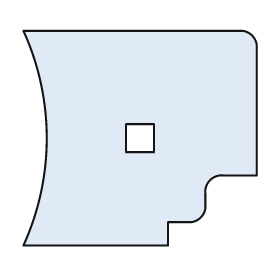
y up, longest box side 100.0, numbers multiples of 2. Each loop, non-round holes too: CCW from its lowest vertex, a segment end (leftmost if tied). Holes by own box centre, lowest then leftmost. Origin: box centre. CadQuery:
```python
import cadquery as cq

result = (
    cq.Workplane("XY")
    .moveTo(-50.0, -46.0)
    .lineTo(12.0, -46.0)
    .lineTo(12.0, -36.0)
    .lineTo(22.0, -36.0)
    .threePointArc((26.0, -34.0), (28.0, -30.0))
    .lineTo(28.0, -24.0)
    .threePointArc((30.0, -18.0), (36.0, -16.0))
    .lineTo(50.0, -16.0)
    .lineTo(50.0, 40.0)
    .threePointArc((48.0, 44.0), (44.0, 46.0))
    .lineTo(-50.0, 46.0)
    .threePointArc((-40.0, 0.0), (-50.0, -46.0))
    .close()
    .moveTo(-6.0, -6.0)
    .lineTo(6.0, -6.0)
    .lineTo(6.0, 6.0)
    .lineTo(-6.0, 6.0)
    .close()
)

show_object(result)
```